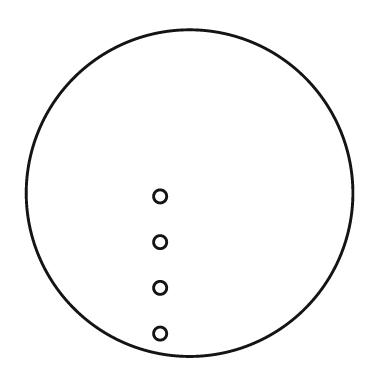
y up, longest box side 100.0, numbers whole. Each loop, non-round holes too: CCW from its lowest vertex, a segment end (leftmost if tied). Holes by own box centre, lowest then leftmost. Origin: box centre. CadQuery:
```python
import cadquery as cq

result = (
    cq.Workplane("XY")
    .moveTo(0.0, 0.0)
    .circle(50.0)
    .moveTo(-9.0, -43.0)
    .circle(2.0)
    .moveTo(-9.0, -29.0)
    .circle(2.0)
    .moveTo(-9.0, -15.0)
    .circle(2.0)
    .moveTo(-9.0, -1.0)
    .circle(2.0)
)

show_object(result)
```